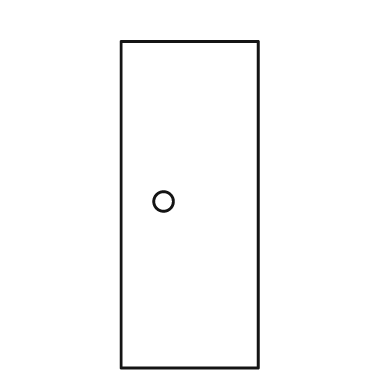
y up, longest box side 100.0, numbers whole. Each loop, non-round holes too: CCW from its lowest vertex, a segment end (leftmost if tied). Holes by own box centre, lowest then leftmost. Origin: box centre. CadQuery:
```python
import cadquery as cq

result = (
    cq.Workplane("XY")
    .moveTo(-21.0, -50.0)
    .lineTo(21.0, -50.0)
    .lineTo(21.0, 50.0)
    .lineTo(-21.0, 50.0)
    .close()
    .moveTo(-8.0, 1.0)
    .circle(3.0)
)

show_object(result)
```